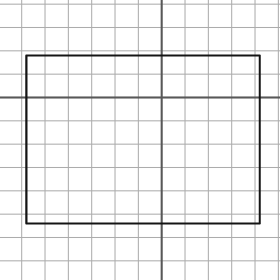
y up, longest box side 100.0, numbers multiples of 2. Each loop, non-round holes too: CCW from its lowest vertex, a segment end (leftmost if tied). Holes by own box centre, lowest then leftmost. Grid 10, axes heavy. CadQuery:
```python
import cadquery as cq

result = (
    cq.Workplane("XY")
    .moveTo(-58.0, -54.0)
    .lineTo(42.0, -54.0)
    .lineTo(42.0, 18.0)
    .lineTo(-58.0, 18.0)
    .close()
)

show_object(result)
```